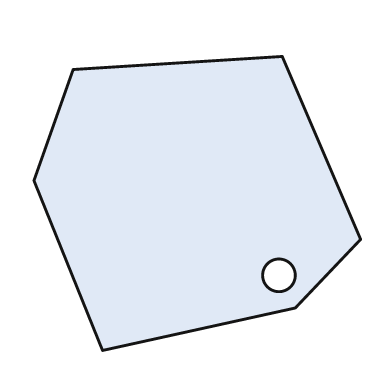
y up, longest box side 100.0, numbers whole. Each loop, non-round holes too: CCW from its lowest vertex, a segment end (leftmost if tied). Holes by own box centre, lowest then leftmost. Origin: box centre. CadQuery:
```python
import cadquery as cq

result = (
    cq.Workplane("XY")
    .moveTo(-29.0, -45.0)
    .lineTo(30.0, -32.0)
    .lineTo(50.0, -11.0)
    .lineTo(26.0, 45.0)
    .lineTo(-38.0, 41.0)
    .lineTo(-50.0, 7.0)
    .close()
    .moveTo(25.0, -22.0)
    .circle(5.0)
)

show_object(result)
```